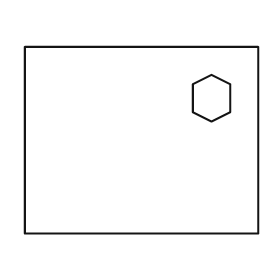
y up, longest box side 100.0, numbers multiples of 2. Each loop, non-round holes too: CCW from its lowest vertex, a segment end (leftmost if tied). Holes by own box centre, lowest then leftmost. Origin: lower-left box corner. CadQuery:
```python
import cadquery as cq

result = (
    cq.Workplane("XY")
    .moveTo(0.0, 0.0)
    .lineTo(100.0, 0.0)
    .lineTo(100.0, 80.0)
    .lineTo(0.0, 80.0)
    .close()
    .moveTo(80.0, 48.0)
    .lineTo(88.0, 52.0)
    .lineTo(88.0, 64.0)
    .lineTo(80.0, 68.0)
    .lineTo(72.0, 64.0)
    .lineTo(72.0, 52.0)
    .close()
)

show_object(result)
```